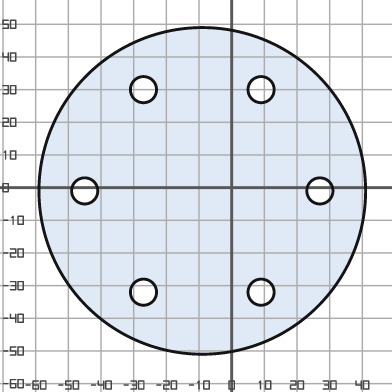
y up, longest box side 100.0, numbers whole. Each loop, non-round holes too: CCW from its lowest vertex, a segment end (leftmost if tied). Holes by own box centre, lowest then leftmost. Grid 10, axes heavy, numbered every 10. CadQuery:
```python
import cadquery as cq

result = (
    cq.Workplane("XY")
    .moveTo(-9.0, -1.0)
    .circle(50.0)
    .moveTo(-27.0, -32.0)
    .circle(4.0)
    .moveTo(9.0, -32.0)
    .circle(4.0)
    .moveTo(-45.0, -1.0)
    .circle(4.0)
    .moveTo(27.0, -1.0)
    .circle(4.0)
    .moveTo(-27.0, 30.0)
    .circle(4.0)
    .moveTo(9.0, 30.0)
    .circle(4.0)
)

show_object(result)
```